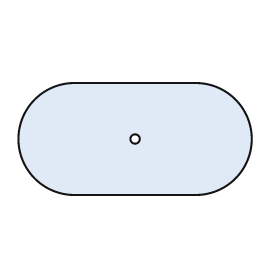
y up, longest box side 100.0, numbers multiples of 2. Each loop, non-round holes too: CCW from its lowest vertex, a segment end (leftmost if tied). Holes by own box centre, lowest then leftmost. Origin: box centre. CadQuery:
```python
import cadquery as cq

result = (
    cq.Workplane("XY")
    .moveTo(-26.0, -24.0)
    .lineTo(26.0, -24.0)
    .threePointArc((50.0, 0.0), (26.0, 24.0))
    .lineTo(-26.0, 24.0)
    .threePointArc((-50.0, 0.0), (-26.0, -24.0))
    .close()
    .moveTo(0.0, 0.0)
    .circle(2.0)
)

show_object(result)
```